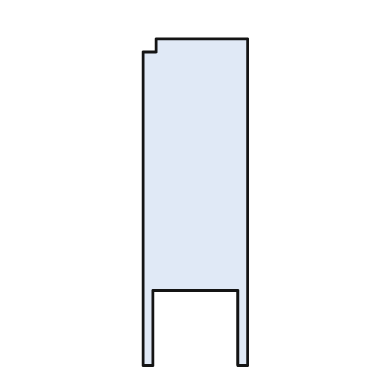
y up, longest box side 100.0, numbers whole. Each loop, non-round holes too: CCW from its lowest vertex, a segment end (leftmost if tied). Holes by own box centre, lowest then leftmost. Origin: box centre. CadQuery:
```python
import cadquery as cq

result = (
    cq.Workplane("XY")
    .moveTo(-16.0, -50.0)
    .lineTo(-13.0, -50.0)
    .lineTo(-13.0, -27.0)
    .lineTo(13.0, -27.0)
    .lineTo(13.0, -50.0)
    .lineTo(16.0, -50.0)
    .lineTo(16.0, 50.0)
    .lineTo(-12.0, 50.0)
    .lineTo(-12.0, 46.0)
    .lineTo(-16.0, 46.0)
    .close()
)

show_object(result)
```